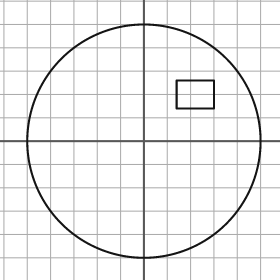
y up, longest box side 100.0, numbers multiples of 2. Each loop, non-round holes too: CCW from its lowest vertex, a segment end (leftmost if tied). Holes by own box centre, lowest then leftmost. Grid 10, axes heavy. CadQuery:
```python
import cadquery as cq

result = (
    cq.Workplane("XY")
    .moveTo(0.0, 0.0)
    .circle(50.0)
    .moveTo(14.0, 14.0)
    .lineTo(30.0, 14.0)
    .lineTo(30.0, 26.0)
    .lineTo(14.0, 26.0)
    .close()
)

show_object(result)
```